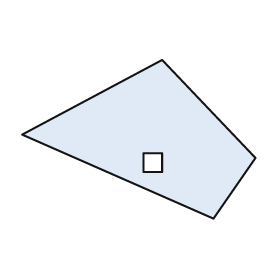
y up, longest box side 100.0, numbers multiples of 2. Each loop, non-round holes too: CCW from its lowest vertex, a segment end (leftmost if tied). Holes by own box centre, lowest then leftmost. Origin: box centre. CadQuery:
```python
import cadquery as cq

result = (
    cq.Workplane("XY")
    .moveTo(32.0, -34.0)
    .lineTo(50.0, -8.0)
    .lineTo(10.0, 34.0)
    .lineTo(-50.0, 2.0)
    .close()
    .moveTo(2.0, -14.0)
    .lineTo(10.0, -14.0)
    .lineTo(10.0, -6.0)
    .lineTo(2.0, -6.0)
    .close()
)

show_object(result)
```